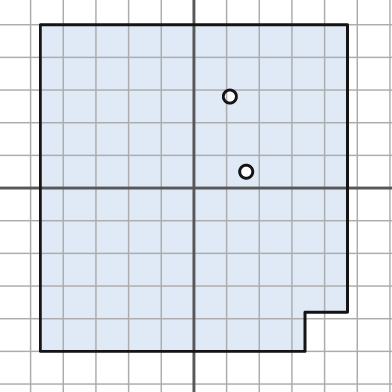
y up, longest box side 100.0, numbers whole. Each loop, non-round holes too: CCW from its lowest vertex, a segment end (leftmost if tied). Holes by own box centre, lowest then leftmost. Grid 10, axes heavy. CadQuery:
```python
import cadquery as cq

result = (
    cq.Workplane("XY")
    .moveTo(-47.0, -50.0)
    .lineTo(34.0, -50.0)
    .lineTo(34.0, -38.0)
    .lineTo(47.0, -38.0)
    .lineTo(47.0, 50.0)
    .lineTo(-47.0, 50.0)
    .close()
    .moveTo(16.0, 5.0)
    .circle(2.0)
    .moveTo(11.0, 28.0)
    .circle(2.0)
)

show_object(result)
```